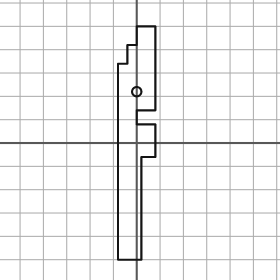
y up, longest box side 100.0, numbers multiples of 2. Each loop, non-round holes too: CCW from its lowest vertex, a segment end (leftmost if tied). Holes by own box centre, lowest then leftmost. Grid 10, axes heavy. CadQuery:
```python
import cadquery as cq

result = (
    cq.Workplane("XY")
    .moveTo(-8.0, -50.0)
    .lineTo(2.0, -50.0)
    .lineTo(2.0, -6.0)
    .lineTo(8.0, -6.0)
    .lineTo(8.0, 8.0)
    .lineTo(0.0, 8.0)
    .lineTo(0.0, 14.0)
    .lineTo(8.0, 14.0)
    .lineTo(8.0, 50.0)
    .lineTo(0.0, 50.0)
    .lineTo(0.0, 42.0)
    .lineTo(-4.0, 42.0)
    .lineTo(-4.0, 34.0)
    .lineTo(-8.0, 34.0)
    .close()
    .moveTo(0.0, 22.0)
    .circle(2.0)
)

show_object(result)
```